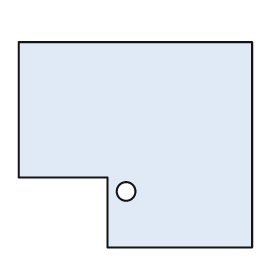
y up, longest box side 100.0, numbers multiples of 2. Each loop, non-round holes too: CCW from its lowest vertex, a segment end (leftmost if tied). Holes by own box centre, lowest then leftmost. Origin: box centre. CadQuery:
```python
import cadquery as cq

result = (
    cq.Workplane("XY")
    .moveTo(-12.0, -44.0)
    .lineTo(50.0, -44.0)
    .lineTo(50.0, 44.0)
    .lineTo(-50.0, 44.0)
    .lineTo(-50.0, -14.0)
    .lineTo(-12.0, -14.0)
    .close()
    .moveTo(-4.0, -20.0)
    .circle(4.0)
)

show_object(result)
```